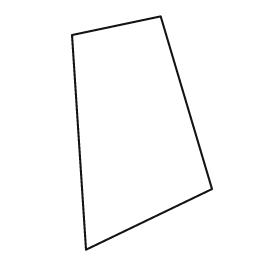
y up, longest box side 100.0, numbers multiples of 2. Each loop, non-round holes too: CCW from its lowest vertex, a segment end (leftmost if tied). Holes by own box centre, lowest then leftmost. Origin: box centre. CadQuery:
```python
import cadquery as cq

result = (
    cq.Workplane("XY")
    .moveTo(-24.0, -50.0)
    .lineTo(30.0, -24.0)
    .lineTo(8.0, 50.0)
    .lineTo(-30.0, 42.0)
    .close()
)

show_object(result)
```